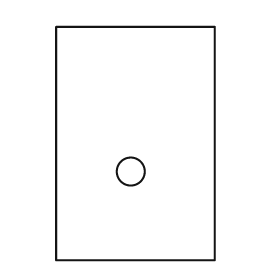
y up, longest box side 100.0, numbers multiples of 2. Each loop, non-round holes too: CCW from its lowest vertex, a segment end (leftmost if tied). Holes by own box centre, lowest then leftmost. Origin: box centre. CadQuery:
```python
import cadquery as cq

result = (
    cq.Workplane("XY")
    .moveTo(-34.0, -50.0)
    .lineTo(34.0, -50.0)
    .lineTo(34.0, 50.0)
    .lineTo(-34.0, 50.0)
    .close()
    .moveTo(-2.0, -12.0)
    .circle(6.0)
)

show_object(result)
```